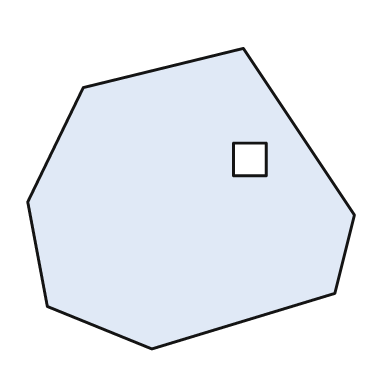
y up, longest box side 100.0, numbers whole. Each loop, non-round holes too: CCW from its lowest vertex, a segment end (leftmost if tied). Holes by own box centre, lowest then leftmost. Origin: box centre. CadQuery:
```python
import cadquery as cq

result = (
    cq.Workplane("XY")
    .moveTo(-12.0, -46.0)
    .lineTo(44.0, -29.0)
    .lineTo(50.0, -5.0)
    .lineTo(16.0, 46.0)
    .lineTo(-33.0, 34.0)
    .lineTo(-50.0, -1.0)
    .lineTo(-44.0, -33.0)
    .close()
    .moveTo(13.0, 7.0)
    .lineTo(23.0, 7.0)
    .lineTo(23.0, 17.0)
    .lineTo(13.0, 17.0)
    .close()
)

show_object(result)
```